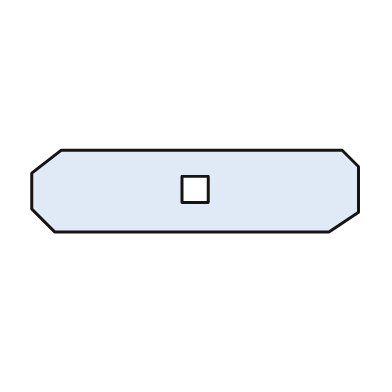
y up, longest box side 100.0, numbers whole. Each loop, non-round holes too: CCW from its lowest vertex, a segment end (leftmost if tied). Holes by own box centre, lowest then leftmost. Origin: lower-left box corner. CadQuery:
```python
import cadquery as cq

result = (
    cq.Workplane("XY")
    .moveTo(7.0, 0.0)
    .lineTo(91.0, 0.0)
    .lineTo(100.0, 6.0)
    .lineTo(100.0, 20.0)
    .lineTo(95.0, 25.0)
    .lineTo(9.0, 25.0)
    .lineTo(0.0, 18.0)
    .lineTo(0.0, 7.0)
    .close()
    .moveTo(46.0, 9.0)
    .lineTo(54.0, 9.0)
    .lineTo(54.0, 17.0)
    .lineTo(46.0, 17.0)
    .close()
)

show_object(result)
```